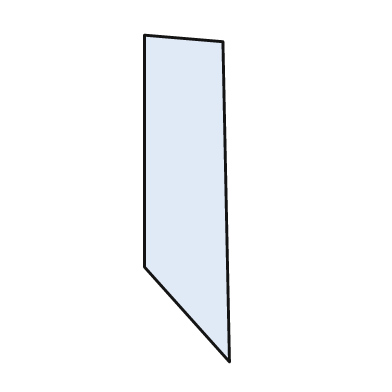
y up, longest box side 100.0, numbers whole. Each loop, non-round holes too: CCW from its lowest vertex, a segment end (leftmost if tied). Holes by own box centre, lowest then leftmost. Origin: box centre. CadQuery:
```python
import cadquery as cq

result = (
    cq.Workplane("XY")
    .moveTo(13.0, -50.0)
    .lineTo(11.0, 48.0)
    .lineTo(-13.0, 50.0)
    .lineTo(-13.0, -21.0)
    .close()
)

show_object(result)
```